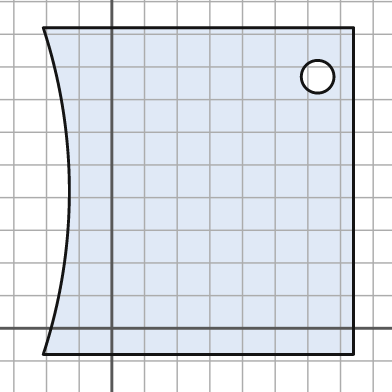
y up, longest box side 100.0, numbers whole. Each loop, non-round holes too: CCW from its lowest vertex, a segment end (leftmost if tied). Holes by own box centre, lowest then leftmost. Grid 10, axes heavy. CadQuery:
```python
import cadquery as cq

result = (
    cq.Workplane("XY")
    .moveTo(-21.0, -8.0)
    .lineTo(74.0, -8.0)
    .lineTo(74.0, 92.0)
    .lineTo(-21.0, 92.0)
    .threePointArc((-13.0, 42.0), (-21.0, -8.0))
    .close()
    .moveTo(63.0, 77.0)
    .circle(5.0)
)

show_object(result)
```